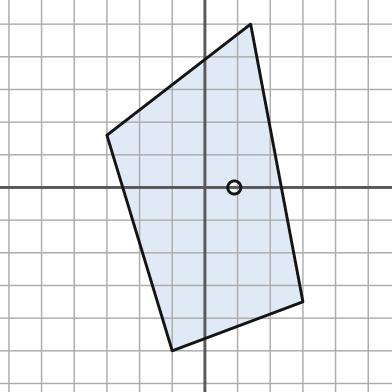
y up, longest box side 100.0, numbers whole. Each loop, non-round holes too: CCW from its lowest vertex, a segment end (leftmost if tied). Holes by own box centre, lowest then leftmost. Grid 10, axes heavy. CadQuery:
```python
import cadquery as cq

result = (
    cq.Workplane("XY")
    .moveTo(-10.0, -50.0)
    .lineTo(30.0, -35.0)
    .lineTo(14.0, 50.0)
    .lineTo(-30.0, 16.0)
    .close()
    .moveTo(9.0, 0.0)
    .circle(2.0)
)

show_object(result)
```